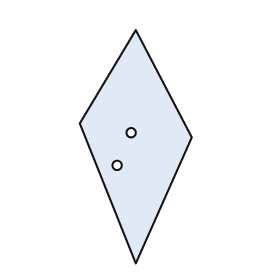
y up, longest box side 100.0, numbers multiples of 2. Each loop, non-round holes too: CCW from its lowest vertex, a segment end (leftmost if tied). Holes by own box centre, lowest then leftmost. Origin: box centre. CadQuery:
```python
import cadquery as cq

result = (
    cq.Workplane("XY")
    .moveTo(0.0, -50.0)
    .lineTo(24.0, 4.0)
    .lineTo(0.0, 50.0)
    .lineTo(-24.0, 10.0)
    .close()
    .moveTo(-8.0, -8.0)
    .circle(2.0)
    .moveTo(-2.0, 6.0)
    .circle(2.0)
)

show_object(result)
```